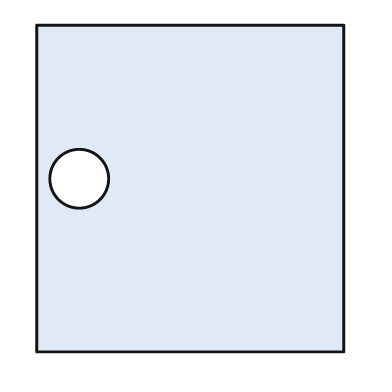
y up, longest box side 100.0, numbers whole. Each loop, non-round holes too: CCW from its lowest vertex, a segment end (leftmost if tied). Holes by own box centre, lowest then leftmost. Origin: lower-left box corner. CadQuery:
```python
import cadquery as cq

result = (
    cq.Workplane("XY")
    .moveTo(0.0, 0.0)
    .lineTo(94.0, 0.0)
    .lineTo(94.0, 100.0)
    .lineTo(0.0, 100.0)
    .close()
    .moveTo(13.0, 53.0)
    .circle(9.0)
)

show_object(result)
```